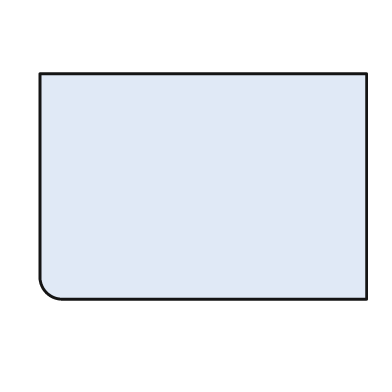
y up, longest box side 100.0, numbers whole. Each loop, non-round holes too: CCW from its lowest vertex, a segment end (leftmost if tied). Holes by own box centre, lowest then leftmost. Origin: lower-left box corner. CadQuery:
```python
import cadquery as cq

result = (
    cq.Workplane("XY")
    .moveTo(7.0, 0.0)
    .lineTo(100.0, 0.0)
    .lineTo(100.0, 69.0)
    .lineTo(0.0, 69.0)
    .lineTo(0.0, 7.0)
    .threePointArc((2.0, 2.0), (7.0, 0.0))
    .close()
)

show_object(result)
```